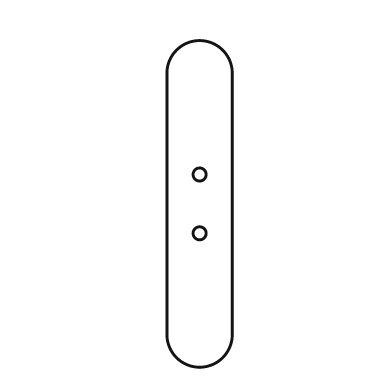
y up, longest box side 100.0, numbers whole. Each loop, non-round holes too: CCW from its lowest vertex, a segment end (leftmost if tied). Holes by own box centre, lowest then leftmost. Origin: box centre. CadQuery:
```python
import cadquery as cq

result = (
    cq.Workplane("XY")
    .moveTo(-10.0, -40.0)
    .threePointArc((0.0, -50.0), (10.0, -40.0))
    .lineTo(10.0, 40.0)
    .threePointArc((0.0, 50.0), (-10.0, 40.0))
    .close()
    .moveTo(0.0, -9.0)
    .circle(2.0)
    .moveTo(0.0, 9.0)
    .circle(2.0)
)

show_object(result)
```